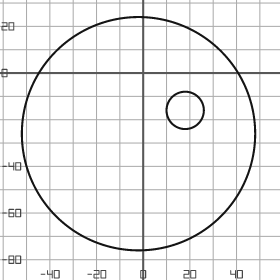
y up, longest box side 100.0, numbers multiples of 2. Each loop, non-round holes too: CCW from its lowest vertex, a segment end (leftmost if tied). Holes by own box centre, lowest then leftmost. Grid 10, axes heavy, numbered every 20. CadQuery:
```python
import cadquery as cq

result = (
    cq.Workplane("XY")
    .moveTo(-2.0, -26.0)
    .circle(50.0)
    .moveTo(18.0, -16.0)
    .circle(8.0)
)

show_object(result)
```